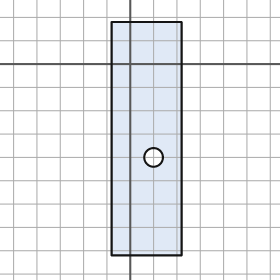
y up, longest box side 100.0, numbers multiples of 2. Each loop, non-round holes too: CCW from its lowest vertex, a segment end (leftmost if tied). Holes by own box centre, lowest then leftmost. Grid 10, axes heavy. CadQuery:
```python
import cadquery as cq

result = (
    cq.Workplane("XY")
    .moveTo(-8.0, -82.0)
    .lineTo(22.0, -82.0)
    .lineTo(22.0, 18.0)
    .lineTo(-8.0, 18.0)
    .close()
    .moveTo(10.0, -40.0)
    .circle(4.0)
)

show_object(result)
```